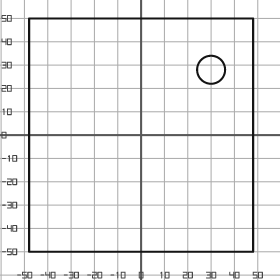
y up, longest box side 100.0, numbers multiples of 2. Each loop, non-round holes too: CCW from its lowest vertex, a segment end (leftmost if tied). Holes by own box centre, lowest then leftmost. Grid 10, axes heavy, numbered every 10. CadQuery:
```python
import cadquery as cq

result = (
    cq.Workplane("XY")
    .moveTo(-48.0, -50.0)
    .lineTo(48.0, -50.0)
    .lineTo(48.0, 50.0)
    .lineTo(-48.0, 50.0)
    .close()
    .moveTo(30.0, 28.0)
    .circle(6.0)
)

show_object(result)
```